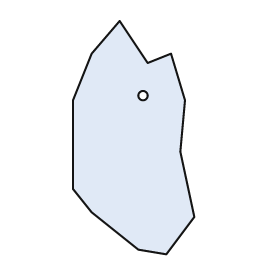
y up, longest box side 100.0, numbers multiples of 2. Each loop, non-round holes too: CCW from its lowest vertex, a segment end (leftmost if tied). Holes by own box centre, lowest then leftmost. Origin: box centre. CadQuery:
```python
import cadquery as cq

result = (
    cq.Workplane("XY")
    .moveTo(14.0, -50.0)
    .lineTo(26.0, -34.0)
    .lineTo(20.0, -6.0)
    .lineTo(22.0, 16.0)
    .lineTo(16.0, 36.0)
    .lineTo(6.0, 32.0)
    .lineTo(-6.0, 50.0)
    .lineTo(-18.0, 36.0)
    .lineTo(-26.0, 16.0)
    .lineTo(-26.0, -22.0)
    .lineTo(-18.0, -32.0)
    .lineTo(2.0, -48.0)
    .close()
    .moveTo(4.0, 18.0)
    .circle(2.0)
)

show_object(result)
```